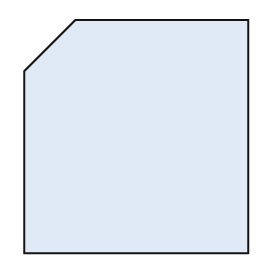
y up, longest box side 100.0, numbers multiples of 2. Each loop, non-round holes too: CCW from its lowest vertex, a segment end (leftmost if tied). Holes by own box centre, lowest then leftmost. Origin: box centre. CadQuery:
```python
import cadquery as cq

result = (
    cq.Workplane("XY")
    .moveTo(-48.0, -50.0)
    .lineTo(48.0, -50.0)
    .lineTo(48.0, 50.0)
    .lineTo(-26.0, 50.0)
    .lineTo(-48.0, 28.0)
    .close()
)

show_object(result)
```